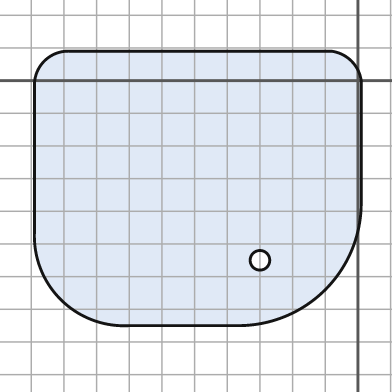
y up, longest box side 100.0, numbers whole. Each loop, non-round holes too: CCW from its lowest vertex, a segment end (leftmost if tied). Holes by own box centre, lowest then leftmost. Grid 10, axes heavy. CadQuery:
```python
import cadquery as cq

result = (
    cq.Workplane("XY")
    .moveTo(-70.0, -75.0)
    .lineTo(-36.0, -75.0)
    .threePointArc((-10.0, -64.0), (1.0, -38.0))
    .lineTo(1.0, 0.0)
    .threePointArc((-2.0, 6.0), (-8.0, 9.0))
    .lineTo(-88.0, 9.0)
    .threePointArc((-96.0, 6.0), (-99.0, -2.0))
    .lineTo(-99.0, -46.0)
    .threePointArc((-91.0, -67.0), (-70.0, -75.0))
    .close()
    .moveTo(-30.0, -55.0)
    .circle(3.0)
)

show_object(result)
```